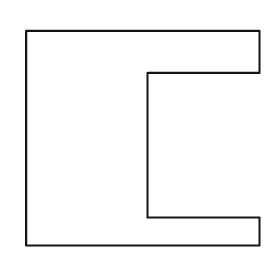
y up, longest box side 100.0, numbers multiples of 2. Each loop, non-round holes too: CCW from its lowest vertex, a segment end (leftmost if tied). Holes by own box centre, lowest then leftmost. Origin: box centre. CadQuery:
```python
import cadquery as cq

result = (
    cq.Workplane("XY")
    .moveTo(-50.0, -46.0)
    .lineTo(50.0, -46.0)
    .lineTo(50.0, -34.0)
    .lineTo(2.0, -34.0)
    .lineTo(2.0, 28.0)
    .lineTo(50.0, 28.0)
    .lineTo(50.0, 46.0)
    .lineTo(-50.0, 46.0)
    .close()
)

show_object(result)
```